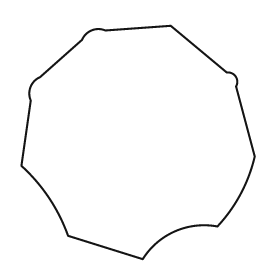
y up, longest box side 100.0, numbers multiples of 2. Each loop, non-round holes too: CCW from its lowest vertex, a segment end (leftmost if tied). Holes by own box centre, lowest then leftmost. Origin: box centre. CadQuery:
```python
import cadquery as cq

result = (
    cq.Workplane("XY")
    .moveTo(2.0, -50.0)
    .threePointArc((16.0, -38.0), (34.0, -36.0))
    .threePointArc((44.0, -22.0), (50.0, -6.0))
    .lineTo(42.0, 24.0)
    .threePointArc((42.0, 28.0), (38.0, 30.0))
    .lineTo(14.0, 50.0)
    .lineTo(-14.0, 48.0)
    .threePointArc((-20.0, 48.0), (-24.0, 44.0))
    .lineTo(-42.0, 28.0)
    .threePointArc((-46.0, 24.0), (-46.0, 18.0))
    .lineTo(-50.0, -10.0)
    .threePointArc((-38.0, -24.0), (-30.0, -40.0))
    .close()
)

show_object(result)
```